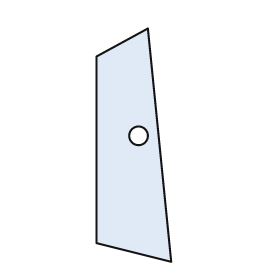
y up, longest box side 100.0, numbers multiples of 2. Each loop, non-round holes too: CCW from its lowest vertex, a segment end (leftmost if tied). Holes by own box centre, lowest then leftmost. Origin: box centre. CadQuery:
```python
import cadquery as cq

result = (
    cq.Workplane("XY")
    .moveTo(16.0, -50.0)
    .lineTo(6.0, 50.0)
    .lineTo(-16.0, 38.0)
    .lineTo(-16.0, -42.0)
    .close()
    .moveTo(2.0, 4.0)
    .circle(4.0)
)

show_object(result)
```